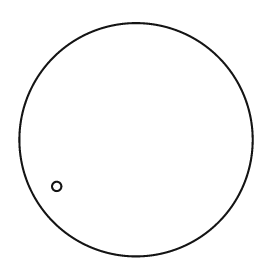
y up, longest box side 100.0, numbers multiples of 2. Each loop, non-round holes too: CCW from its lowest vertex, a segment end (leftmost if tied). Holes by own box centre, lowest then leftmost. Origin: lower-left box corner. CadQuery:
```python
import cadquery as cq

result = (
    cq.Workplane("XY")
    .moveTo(50.0, 50.0)
    .circle(50.0)
    .moveTo(16.0, 30.0)
    .circle(2.0)
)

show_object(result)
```